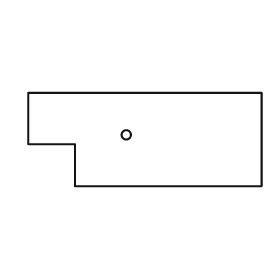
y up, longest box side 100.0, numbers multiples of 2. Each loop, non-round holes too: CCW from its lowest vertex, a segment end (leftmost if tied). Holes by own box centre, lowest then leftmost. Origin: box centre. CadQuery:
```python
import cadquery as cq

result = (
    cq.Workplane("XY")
    .moveTo(-30.0, -20.0)
    .lineTo(50.0, -20.0)
    .lineTo(50.0, 20.0)
    .lineTo(-50.0, 20.0)
    .lineTo(-50.0, -2.0)
    .lineTo(-30.0, -2.0)
    .close()
    .moveTo(-8.0, 2.0)
    .circle(2.0)
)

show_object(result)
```